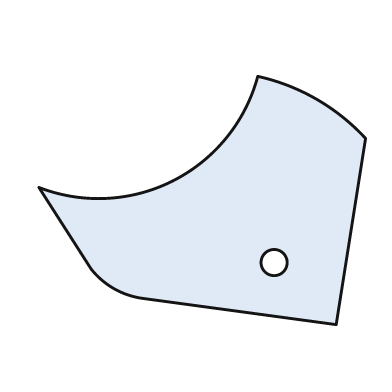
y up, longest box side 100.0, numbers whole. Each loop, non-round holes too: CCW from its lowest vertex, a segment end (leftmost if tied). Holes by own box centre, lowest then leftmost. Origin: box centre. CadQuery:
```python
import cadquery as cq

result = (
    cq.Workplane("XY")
    .moveTo(41.0, -38.0)
    .lineTo(50.0, 19.0)
    .threePointArc((35.0, 31.0), (17.0, 38.0))
    .threePointArc((-9.0, 6.0), (-50.0, 4.0))
    .lineTo(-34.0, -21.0)
    .threePointArc((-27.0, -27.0), (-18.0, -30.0))
    .close()
    .moveTo(22.0, -19.0)
    .circle(4.0)
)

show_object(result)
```